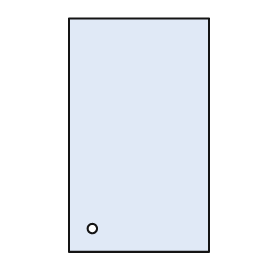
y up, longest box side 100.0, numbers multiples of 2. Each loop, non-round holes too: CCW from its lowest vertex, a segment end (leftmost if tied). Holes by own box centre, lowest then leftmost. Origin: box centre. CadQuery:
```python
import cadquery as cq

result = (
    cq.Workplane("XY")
    .moveTo(-30.0, -50.0)
    .lineTo(30.0, -50.0)
    .lineTo(30.0, 50.0)
    .lineTo(-30.0, 50.0)
    .close()
    .moveTo(-20.0, -40.0)
    .circle(2.0)
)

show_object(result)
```